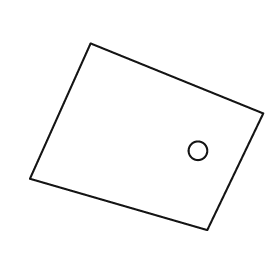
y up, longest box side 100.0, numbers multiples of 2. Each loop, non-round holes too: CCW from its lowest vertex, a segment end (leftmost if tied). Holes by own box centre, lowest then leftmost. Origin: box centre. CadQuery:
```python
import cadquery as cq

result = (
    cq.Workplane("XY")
    .moveTo(26.0, -40.0)
    .lineTo(50.0, 10.0)
    .lineTo(-24.0, 40.0)
    .lineTo(-50.0, -18.0)
    .close()
    .moveTo(22.0, -6.0)
    .circle(4.0)
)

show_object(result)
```